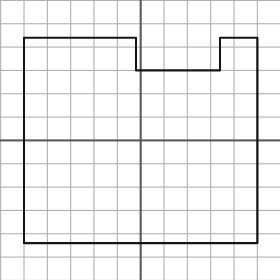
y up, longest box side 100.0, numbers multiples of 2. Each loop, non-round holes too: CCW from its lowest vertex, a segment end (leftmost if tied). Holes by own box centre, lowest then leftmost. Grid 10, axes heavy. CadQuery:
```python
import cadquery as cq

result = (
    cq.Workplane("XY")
    .moveTo(-50.0, -44.0)
    .lineTo(50.0, -44.0)
    .lineTo(50.0, 44.0)
    .lineTo(34.0, 44.0)
    .lineTo(34.0, 30.0)
    .lineTo(-2.0, 30.0)
    .lineTo(-2.0, 44.0)
    .lineTo(-50.0, 44.0)
    .close()
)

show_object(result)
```